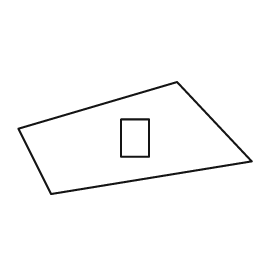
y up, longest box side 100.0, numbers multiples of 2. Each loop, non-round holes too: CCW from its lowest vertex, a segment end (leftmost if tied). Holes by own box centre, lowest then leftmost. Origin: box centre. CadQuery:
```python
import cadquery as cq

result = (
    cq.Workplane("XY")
    .moveTo(-36.0, -24.0)
    .lineTo(50.0, -10.0)
    .lineTo(18.0, 24.0)
    .lineTo(-50.0, 4.0)
    .close()
    .moveTo(-6.0, -8.0)
    .lineTo(6.0, -8.0)
    .lineTo(6.0, 8.0)
    .lineTo(-6.0, 8.0)
    .close()
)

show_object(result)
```